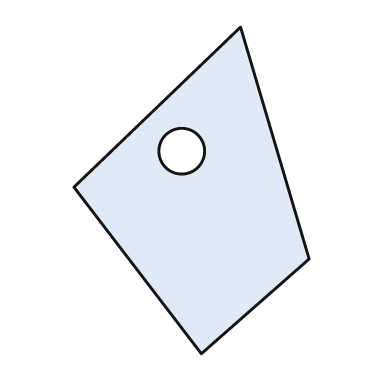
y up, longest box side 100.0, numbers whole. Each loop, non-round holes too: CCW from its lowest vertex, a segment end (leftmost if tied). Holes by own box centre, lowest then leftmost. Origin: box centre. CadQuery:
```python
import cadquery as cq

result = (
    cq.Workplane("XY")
    .moveTo(3.0, -50.0)
    .lineTo(36.0, -21.0)
    .lineTo(15.0, 50.0)
    .lineTo(-36.0, 1.0)
    .close()
    .moveTo(-3.0, 12.0)
    .circle(7.0)
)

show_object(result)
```